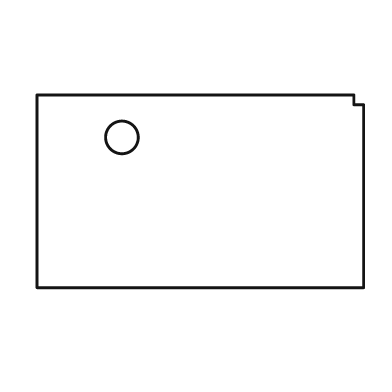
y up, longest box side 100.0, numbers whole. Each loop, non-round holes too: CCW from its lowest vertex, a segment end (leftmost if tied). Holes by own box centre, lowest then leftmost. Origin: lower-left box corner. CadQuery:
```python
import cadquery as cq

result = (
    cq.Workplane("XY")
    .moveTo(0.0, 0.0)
    .lineTo(100.0, 0.0)
    .lineTo(100.0, 56.0)
    .lineTo(97.0, 56.0)
    .lineTo(97.0, 59.0)
    .lineTo(0.0, 59.0)
    .close()
    .moveTo(26.0, 46.0)
    .circle(5.0)
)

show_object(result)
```